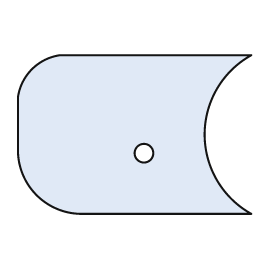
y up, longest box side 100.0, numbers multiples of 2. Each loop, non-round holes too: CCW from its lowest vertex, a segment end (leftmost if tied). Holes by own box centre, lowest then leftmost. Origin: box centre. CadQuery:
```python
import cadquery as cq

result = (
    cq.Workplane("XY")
    .moveTo(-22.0, -34.0)
    .lineTo(50.0, -34.0)
    .threePointArc((30.0, 0.0), (50.0, 34.0))
    .lineTo(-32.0, 34.0)
    .threePointArc((-44.0, 28.0), (-50.0, 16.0))
    .lineTo(-50.0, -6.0)
    .threePointArc((-42.0, -26.0), (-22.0, -34.0))
    .close()
    .moveTo(4.0, -8.0)
    .circle(4.0)
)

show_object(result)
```